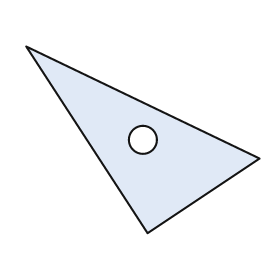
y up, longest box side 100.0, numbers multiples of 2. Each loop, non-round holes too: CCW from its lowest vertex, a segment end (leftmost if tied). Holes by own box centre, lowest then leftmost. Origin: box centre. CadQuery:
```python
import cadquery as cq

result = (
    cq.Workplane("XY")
    .moveTo(2.0, -40.0)
    .lineTo(50.0, -8.0)
    .lineTo(-50.0, 40.0)
    .close()
    .moveTo(0.0, 0.0)
    .circle(6.0)
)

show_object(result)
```